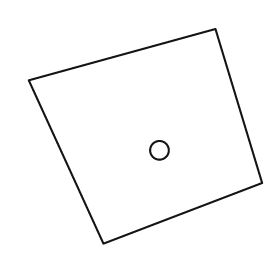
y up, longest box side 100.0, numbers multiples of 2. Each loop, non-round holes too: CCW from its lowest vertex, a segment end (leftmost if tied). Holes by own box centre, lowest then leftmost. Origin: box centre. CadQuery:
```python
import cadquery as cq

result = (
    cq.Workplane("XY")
    .moveTo(-18.0, -46.0)
    .lineTo(50.0, -20.0)
    .lineTo(30.0, 46.0)
    .lineTo(-50.0, 24.0)
    .close()
    .moveTo(6.0, -6.0)
    .circle(4.0)
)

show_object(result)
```